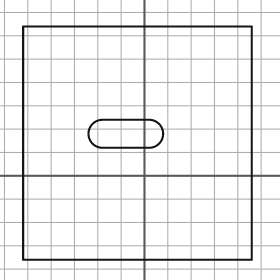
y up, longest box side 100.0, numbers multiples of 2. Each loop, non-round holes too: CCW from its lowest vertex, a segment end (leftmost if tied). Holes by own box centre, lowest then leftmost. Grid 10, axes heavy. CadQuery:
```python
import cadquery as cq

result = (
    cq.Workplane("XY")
    .moveTo(-52.0, -36.0)
    .lineTo(46.0, -36.0)
    .lineTo(46.0, 64.0)
    .lineTo(-52.0, 64.0)
    .close()
    .moveTo(-18.0, 12.0)
    .lineTo(2.0, 12.0)
    .threePointArc((8.0, 18.0), (2.0, 24.0))
    .lineTo(-18.0, 24.0)
    .threePointArc((-24.0, 18.0), (-18.0, 12.0))
    .close()
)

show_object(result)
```